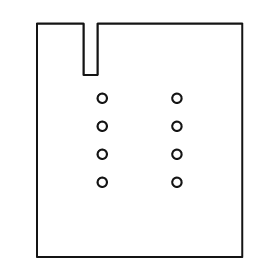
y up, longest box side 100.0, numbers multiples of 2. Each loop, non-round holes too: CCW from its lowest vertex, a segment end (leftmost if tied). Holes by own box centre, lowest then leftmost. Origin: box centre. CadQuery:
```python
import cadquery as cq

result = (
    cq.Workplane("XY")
    .moveTo(-44.0, -50.0)
    .lineTo(44.0, -50.0)
    .lineTo(44.0, 50.0)
    .lineTo(-18.0, 50.0)
    .lineTo(-18.0, 28.0)
    .lineTo(-24.0, 28.0)
    .lineTo(-24.0, 50.0)
    .lineTo(-44.0, 50.0)
    .close()
    .moveTo(-16.0, -18.0)
    .circle(2.0)
    .moveTo(16.0, -18.0)
    .circle(2.0)
    .moveTo(-16.0, -6.0)
    .circle(2.0)
    .moveTo(16.0, -6.0)
    .circle(2.0)
    .moveTo(-16.0, 6.0)
    .circle(2.0)
    .moveTo(16.0, 6.0)
    .circle(2.0)
    .moveTo(-16.0, 18.0)
    .circle(2.0)
    .moveTo(16.0, 18.0)
    .circle(2.0)
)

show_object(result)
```